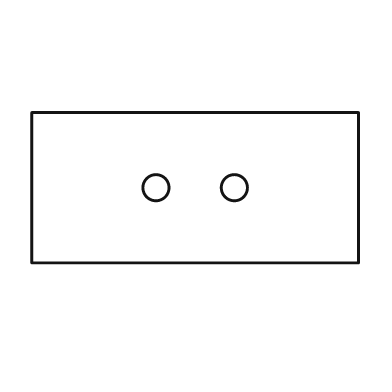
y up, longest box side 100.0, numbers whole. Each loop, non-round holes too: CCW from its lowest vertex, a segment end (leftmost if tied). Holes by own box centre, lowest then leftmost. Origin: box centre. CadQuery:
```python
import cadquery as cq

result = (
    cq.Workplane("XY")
    .moveTo(-50.0, -23.0)
    .lineTo(50.0, -23.0)
    .lineTo(50.0, 23.0)
    .lineTo(-50.0, 23.0)
    .close()
    .moveTo(-12.0, 0.0)
    .circle(4.0)
    .moveTo(12.0, 0.0)
    .circle(4.0)
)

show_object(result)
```